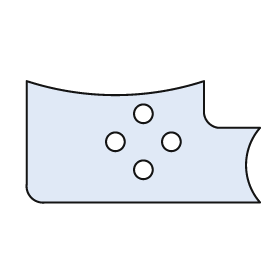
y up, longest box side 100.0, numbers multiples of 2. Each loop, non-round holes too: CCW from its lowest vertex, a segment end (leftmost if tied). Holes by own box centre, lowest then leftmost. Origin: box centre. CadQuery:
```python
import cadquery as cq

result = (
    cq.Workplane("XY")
    .moveTo(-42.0, -26.0)
    .lineTo(50.0, -26.0)
    .threePointArc((44.0, -10.0), (50.0, 6.0))
    .lineTo(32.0, 6.0)
    .threePointArc((28.0, 8.0), (26.0, 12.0))
    .lineTo(26.0, 26.0)
    .threePointArc((-12.0, 20.0), (-50.0, 26.0))
    .lineTo(-50.0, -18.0)
    .threePointArc((-48.0, -24.0), (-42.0, -26.0))
    .close()
    .moveTo(0.0, -12.0)
    .circle(4.0)
    .moveTo(-12.0, 0.0)
    .circle(4.0)
    .moveTo(12.0, 0.0)
    .circle(4.0)
    .moveTo(0.0, 12.0)
    .circle(4.0)
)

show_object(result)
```